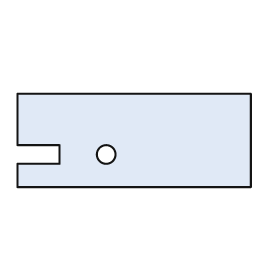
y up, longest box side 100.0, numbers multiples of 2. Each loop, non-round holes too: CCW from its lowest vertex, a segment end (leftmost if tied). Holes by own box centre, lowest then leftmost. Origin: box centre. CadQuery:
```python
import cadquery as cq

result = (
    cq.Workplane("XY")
    .moveTo(-50.0, -20.0)
    .lineTo(50.0, -20.0)
    .lineTo(50.0, 20.0)
    .lineTo(-50.0, 20.0)
    .lineTo(-50.0, -2.0)
    .lineTo(-32.0, -2.0)
    .lineTo(-32.0, -10.0)
    .lineTo(-50.0, -10.0)
    .close()
    .moveTo(-12.0, -6.0)
    .circle(4.0)
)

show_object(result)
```